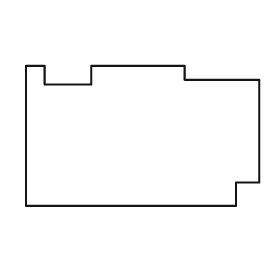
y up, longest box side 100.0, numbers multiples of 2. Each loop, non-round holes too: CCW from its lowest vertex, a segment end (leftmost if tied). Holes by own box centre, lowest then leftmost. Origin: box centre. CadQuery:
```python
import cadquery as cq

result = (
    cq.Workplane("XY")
    .moveTo(-50.0, -30.0)
    .lineTo(40.0, -30.0)
    .lineTo(40.0, -20.0)
    .lineTo(50.0, -20.0)
    .lineTo(50.0, 24.0)
    .lineTo(18.0, 24.0)
    .lineTo(18.0, 30.0)
    .lineTo(-22.0, 30.0)
    .lineTo(-22.0, 22.0)
    .lineTo(-42.0, 22.0)
    .lineTo(-42.0, 30.0)
    .lineTo(-50.0, 30.0)
    .close()
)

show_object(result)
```